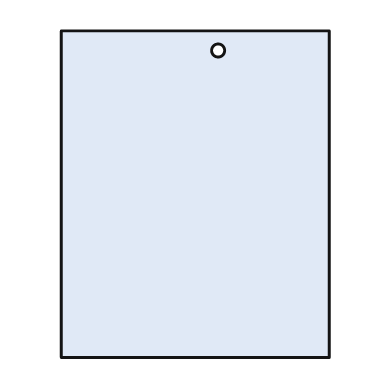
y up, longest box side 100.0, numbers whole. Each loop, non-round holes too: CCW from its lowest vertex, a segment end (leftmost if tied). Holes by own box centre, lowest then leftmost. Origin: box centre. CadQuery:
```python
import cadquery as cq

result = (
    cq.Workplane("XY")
    .moveTo(-41.0, -50.0)
    .lineTo(41.0, -50.0)
    .lineTo(41.0, 50.0)
    .lineTo(-41.0, 50.0)
    .close()
    .moveTo(7.0, 44.0)
    .circle(2.0)
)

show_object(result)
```